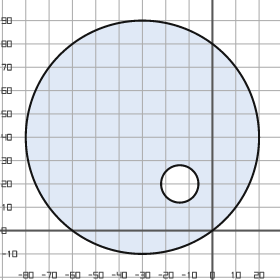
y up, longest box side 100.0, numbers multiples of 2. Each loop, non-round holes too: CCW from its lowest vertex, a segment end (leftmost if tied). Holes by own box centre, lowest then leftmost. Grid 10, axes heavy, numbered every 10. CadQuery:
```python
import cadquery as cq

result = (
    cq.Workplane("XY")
    .moveTo(-30.0, 40.0)
    .circle(50.0)
    .moveTo(-14.0, 20.0)
    .circle(8.0)
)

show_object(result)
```